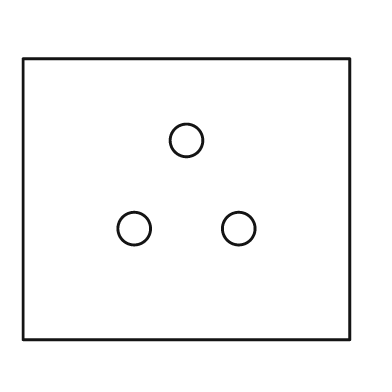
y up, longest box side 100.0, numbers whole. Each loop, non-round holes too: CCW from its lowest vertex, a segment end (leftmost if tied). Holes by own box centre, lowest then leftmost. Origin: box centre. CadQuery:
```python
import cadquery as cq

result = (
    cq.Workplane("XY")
    .moveTo(-50.0, -43.0)
    .lineTo(50.0, -43.0)
    .lineTo(50.0, 43.0)
    .lineTo(-50.0, 43.0)
    .close()
    .moveTo(-16.0, -9.0)
    .circle(5.0)
    .moveTo(16.0, -9.0)
    .circle(5.0)
    .moveTo(0.0, 18.0)
    .circle(5.0)
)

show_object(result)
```